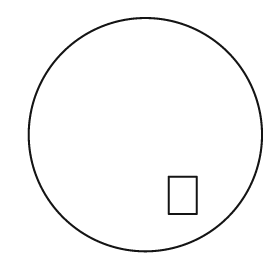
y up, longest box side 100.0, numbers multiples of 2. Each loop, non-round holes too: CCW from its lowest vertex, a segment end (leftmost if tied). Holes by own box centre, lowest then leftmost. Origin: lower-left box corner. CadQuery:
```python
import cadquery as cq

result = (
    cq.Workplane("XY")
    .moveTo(50.0, 50.0)
    .circle(50.0)
    .moveTo(60.0, 16.0)
    .lineTo(72.0, 16.0)
    .lineTo(72.0, 32.0)
    .lineTo(60.0, 32.0)
    .close()
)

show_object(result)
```